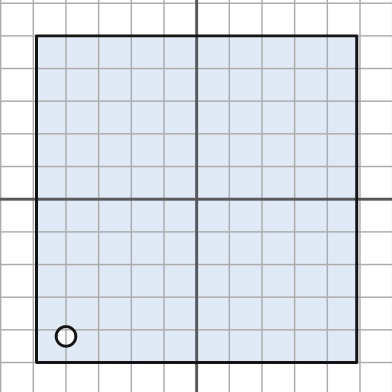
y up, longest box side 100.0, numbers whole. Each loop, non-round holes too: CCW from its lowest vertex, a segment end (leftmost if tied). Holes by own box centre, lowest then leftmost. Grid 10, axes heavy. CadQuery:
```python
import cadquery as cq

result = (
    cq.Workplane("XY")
    .moveTo(-49.0, -50.0)
    .lineTo(49.0, -50.0)
    .lineTo(49.0, 50.0)
    .lineTo(-49.0, 50.0)
    .close()
    .moveTo(-40.0, -42.0)
    .circle(3.0)
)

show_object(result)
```